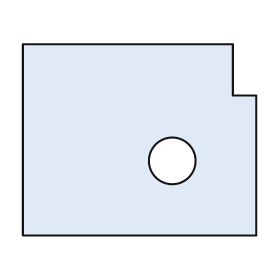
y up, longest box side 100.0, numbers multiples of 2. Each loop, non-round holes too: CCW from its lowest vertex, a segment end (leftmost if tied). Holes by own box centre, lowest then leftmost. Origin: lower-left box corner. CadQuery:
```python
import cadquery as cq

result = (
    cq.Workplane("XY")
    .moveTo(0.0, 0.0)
    .lineTo(100.0, 0.0)
    .lineTo(100.0, 60.0)
    .lineTo(90.0, 60.0)
    .lineTo(90.0, 82.0)
    .lineTo(0.0, 82.0)
    .close()
    .moveTo(64.0, 32.0)
    .circle(10.0)
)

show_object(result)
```